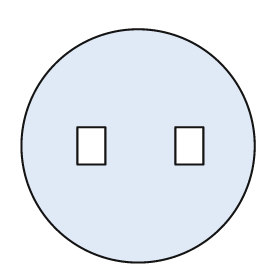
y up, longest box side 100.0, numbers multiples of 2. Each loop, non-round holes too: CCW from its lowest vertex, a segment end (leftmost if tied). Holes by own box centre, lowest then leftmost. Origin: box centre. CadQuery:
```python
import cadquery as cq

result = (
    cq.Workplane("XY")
    .moveTo(0.0, 0.0)
    .circle(50.0)
    .moveTo(-26.0, -8.0)
    .lineTo(-14.0, -8.0)
    .lineTo(-14.0, 8.0)
    .lineTo(-26.0, 8.0)
    .close()
    .moveTo(16.0, -8.0)
    .lineTo(28.0, -8.0)
    .lineTo(28.0, 8.0)
    .lineTo(16.0, 8.0)
    .close()
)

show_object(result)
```